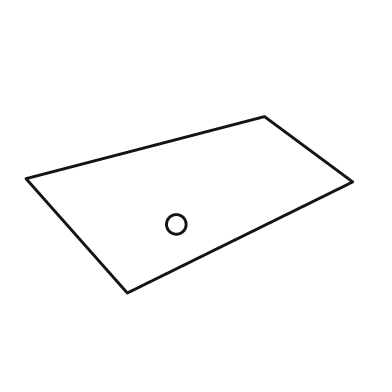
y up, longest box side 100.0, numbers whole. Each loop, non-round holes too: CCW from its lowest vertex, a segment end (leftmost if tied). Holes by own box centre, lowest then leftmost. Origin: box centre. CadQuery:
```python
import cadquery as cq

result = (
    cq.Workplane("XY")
    .moveTo(-19.0, -27.0)
    .lineTo(50.0, 7.0)
    .lineTo(23.0, 27.0)
    .lineTo(-50.0, 8.0)
    .close()
    .moveTo(-4.0, -6.0)
    .circle(3.0)
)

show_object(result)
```